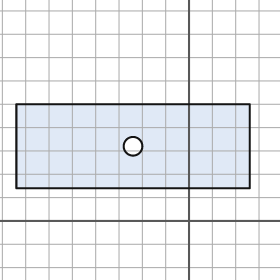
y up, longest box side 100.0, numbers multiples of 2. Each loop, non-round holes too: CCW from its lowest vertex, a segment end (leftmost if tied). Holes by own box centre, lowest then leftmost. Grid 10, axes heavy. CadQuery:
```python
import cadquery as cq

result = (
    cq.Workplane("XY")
    .moveTo(-74.0, 14.0)
    .lineTo(26.0, 14.0)
    .lineTo(26.0, 50.0)
    .lineTo(-74.0, 50.0)
    .close()
    .moveTo(-24.0, 32.0)
    .circle(4.0)
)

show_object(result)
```